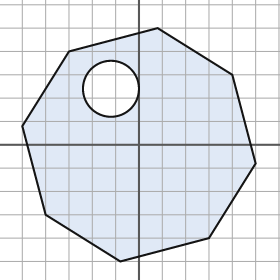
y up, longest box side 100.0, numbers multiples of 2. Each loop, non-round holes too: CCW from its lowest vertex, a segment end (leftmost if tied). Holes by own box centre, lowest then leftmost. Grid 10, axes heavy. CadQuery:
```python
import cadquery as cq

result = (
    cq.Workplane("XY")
    .moveTo(-8.0, -50.0)
    .lineTo(30.0, -40.0)
    .lineTo(50.0, -8.0)
    .lineTo(40.0, 30.0)
    .lineTo(8.0, 50.0)
    .lineTo(-30.0, 40.0)
    .lineTo(-50.0, 8.0)
    .lineTo(-40.0, -30.0)
    .close()
    .moveTo(-12.0, 24.0)
    .circle(12.0)
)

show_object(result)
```